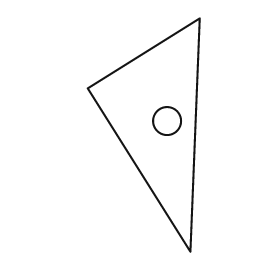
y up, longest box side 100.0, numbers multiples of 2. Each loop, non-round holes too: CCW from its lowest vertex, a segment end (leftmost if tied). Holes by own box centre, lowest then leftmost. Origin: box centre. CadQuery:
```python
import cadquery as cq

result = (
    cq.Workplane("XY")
    .moveTo(20.0, -50.0)
    .lineTo(24.0, 50.0)
    .lineTo(-24.0, 20.0)
    .close()
    .moveTo(10.0, 6.0)
    .circle(6.0)
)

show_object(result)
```